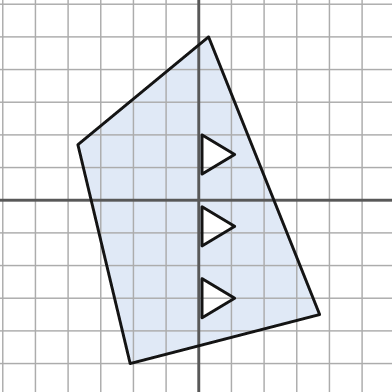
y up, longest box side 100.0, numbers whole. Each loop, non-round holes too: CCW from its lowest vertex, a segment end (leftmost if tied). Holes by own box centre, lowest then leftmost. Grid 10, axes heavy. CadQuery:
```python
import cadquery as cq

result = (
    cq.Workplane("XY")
    .moveTo(-21.0, -50.0)
    .lineTo(37.0, -35.0)
    .lineTo(3.0, 50.0)
    .lineTo(-37.0, 17.0)
    .close()
    .moveTo(1.0, -36.0)
    .lineTo(11.0, -30.0)
    .lineTo(1.0, -24.0)
    .close()
    .moveTo(1.0, -14.0)
    .lineTo(11.0, -8.0)
    .lineTo(1.0, -2.0)
    .close()
    .moveTo(1.0, 8.0)
    .lineTo(11.0, 14.0)
    .lineTo(1.0, 20.0)
    .close()
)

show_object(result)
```